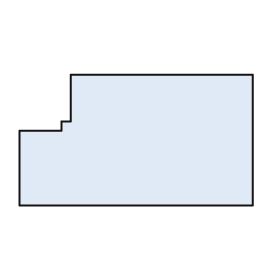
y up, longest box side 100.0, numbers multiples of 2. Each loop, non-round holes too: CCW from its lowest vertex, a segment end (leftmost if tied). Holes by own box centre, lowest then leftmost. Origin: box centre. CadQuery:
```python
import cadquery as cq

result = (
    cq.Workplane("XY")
    .moveTo(-50.0, -28.0)
    .lineTo(50.0, -28.0)
    .lineTo(50.0, 28.0)
    .lineTo(-28.0, 28.0)
    .lineTo(-28.0, 8.0)
    .lineTo(-32.0, 8.0)
    .lineTo(-32.0, 4.0)
    .lineTo(-50.0, 4.0)
    .close()
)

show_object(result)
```